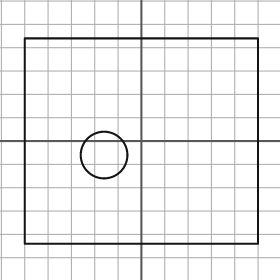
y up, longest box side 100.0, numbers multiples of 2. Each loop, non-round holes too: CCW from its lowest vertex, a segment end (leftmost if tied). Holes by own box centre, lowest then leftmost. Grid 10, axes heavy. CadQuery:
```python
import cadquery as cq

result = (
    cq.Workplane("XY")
    .moveTo(-50.0, -44.0)
    .lineTo(50.0, -44.0)
    .lineTo(50.0, 44.0)
    .lineTo(-50.0, 44.0)
    .close()
    .moveTo(-16.0, -6.0)
    .circle(10.0)
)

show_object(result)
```